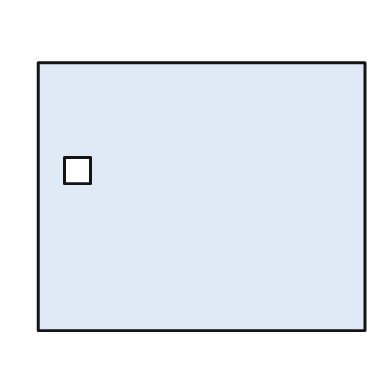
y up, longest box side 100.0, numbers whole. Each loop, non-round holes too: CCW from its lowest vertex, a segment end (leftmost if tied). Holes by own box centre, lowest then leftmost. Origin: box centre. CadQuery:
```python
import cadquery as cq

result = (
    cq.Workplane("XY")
    .moveTo(-50.0, -41.0)
    .lineTo(50.0, -41.0)
    .lineTo(50.0, 41.0)
    .lineTo(-50.0, 41.0)
    .close()
    .moveTo(-42.0, 4.0)
    .lineTo(-34.0, 4.0)
    .lineTo(-34.0, 12.0)
    .lineTo(-42.0, 12.0)
    .close()
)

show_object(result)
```